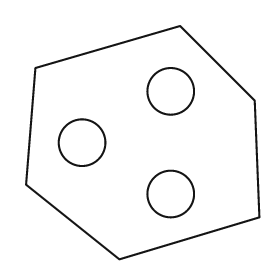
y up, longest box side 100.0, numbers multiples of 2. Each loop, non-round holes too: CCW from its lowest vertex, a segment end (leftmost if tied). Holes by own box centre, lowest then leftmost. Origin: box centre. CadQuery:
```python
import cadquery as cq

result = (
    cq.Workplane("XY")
    .moveTo(-10.0, -50.0)
    .lineTo(50.0, -32.0)
    .lineTo(48.0, 18.0)
    .lineTo(16.0, 50.0)
    .lineTo(-46.0, 32.0)
    .lineTo(-50.0, -18.0)
    .close()
    .moveTo(12.0, -22.0)
    .circle(10.0)
    .moveTo(-26.0, 0.0)
    .circle(10.0)
    .moveTo(12.0, 22.0)
    .circle(10.0)
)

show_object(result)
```